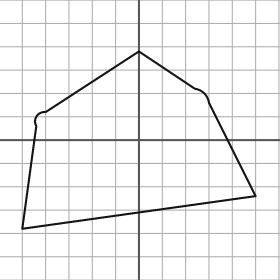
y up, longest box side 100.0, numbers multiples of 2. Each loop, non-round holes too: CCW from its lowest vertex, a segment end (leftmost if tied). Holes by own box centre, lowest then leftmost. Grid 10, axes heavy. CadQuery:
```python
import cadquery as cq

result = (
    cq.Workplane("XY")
    .moveTo(-50.0, -38.0)
    .lineTo(50.0, -24.0)
    .lineTo(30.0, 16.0)
    .threePointArc((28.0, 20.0), (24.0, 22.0))
    .lineTo(0.0, 38.0)
    .lineTo(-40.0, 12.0)
    .threePointArc((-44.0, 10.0), (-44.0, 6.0))
    .close()
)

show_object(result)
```